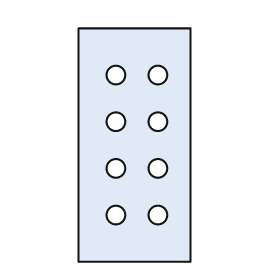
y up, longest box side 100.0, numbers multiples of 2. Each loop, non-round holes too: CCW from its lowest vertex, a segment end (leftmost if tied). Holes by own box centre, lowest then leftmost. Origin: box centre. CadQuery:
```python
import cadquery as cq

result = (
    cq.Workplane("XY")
    .moveTo(-24.0, -50.0)
    .lineTo(24.0, -50.0)
    .lineTo(24.0, 50.0)
    .lineTo(-24.0, 50.0)
    .close()
    .moveTo(-8.0, -30.0)
    .circle(4.0)
    .moveTo(10.0, -30.0)
    .circle(4.0)
    .moveTo(-8.0, -10.0)
    .circle(4.0)
    .moveTo(10.0, -10.0)
    .circle(4.0)
    .moveTo(-8.0, 10.0)
    .circle(4.0)
    .moveTo(10.0, 10.0)
    .circle(4.0)
    .moveTo(-8.0, 30.0)
    .circle(4.0)
    .moveTo(10.0, 30.0)
    .circle(4.0)
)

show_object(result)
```